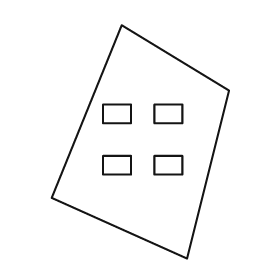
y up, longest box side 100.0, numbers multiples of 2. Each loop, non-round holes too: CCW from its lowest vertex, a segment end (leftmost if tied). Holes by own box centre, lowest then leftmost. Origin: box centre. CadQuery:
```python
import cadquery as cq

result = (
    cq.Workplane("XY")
    .moveTo(20.0, -50.0)
    .lineTo(38.0, 22.0)
    .lineTo(-8.0, 50.0)
    .lineTo(-38.0, -24.0)
    .close()
    .moveTo(-16.0, -14.0)
    .lineTo(-4.0, -14.0)
    .lineTo(-4.0, -6.0)
    .lineTo(-16.0, -6.0)
    .close()
    .moveTo(6.0, -14.0)
    .lineTo(18.0, -14.0)
    .lineTo(18.0, -6.0)
    .lineTo(6.0, -6.0)
    .close()
    .moveTo(-16.0, 8.0)
    .lineTo(-4.0, 8.0)
    .lineTo(-4.0, 16.0)
    .lineTo(-16.0, 16.0)
    .close()
    .moveTo(6.0, 8.0)
    .lineTo(18.0, 8.0)
    .lineTo(18.0, 16.0)
    .lineTo(6.0, 16.0)
    .close()
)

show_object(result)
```